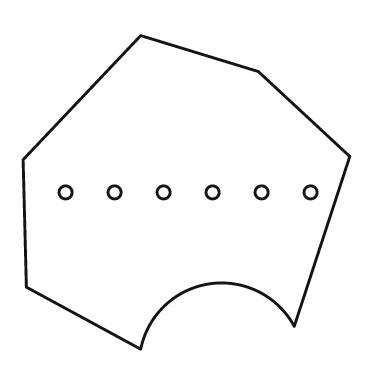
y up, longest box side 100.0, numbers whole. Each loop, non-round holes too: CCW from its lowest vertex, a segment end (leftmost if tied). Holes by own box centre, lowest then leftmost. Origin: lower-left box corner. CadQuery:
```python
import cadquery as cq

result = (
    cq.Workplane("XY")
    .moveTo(36.0, 0.0)
    .threePointArc((57.0, 20.0), (83.0, 7.0))
    .lineTo(100.0, 59.0)
    .lineTo(72.0, 85.0)
    .lineTo(36.0, 96.0)
    .lineTo(0.0, 58.0)
    .lineTo(1.0, 19.0)
    .close()
    .moveTo(13.0, 48.0)
    .circle(2.0)
    .moveTo(28.0, 48.0)
    .circle(2.0)
    .moveTo(43.0, 48.0)
    .circle(2.0)
    .moveTo(58.0, 48.0)
    .circle(2.0)
    .moveTo(73.0, 48.0)
    .circle(2.0)
    .moveTo(88.0, 48.0)
    .circle(2.0)
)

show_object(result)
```